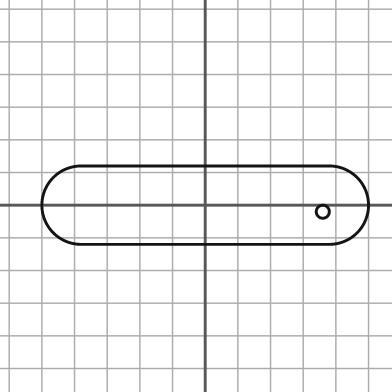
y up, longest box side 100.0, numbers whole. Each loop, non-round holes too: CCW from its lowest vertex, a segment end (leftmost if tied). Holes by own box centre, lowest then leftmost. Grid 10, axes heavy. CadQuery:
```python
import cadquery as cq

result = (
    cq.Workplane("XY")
    .moveTo(-38.0, -12.0)
    .lineTo(38.0, -12.0)
    .threePointArc((50.0, 0.0), (38.0, 12.0))
    .lineTo(-38.0, 12.0)
    .threePointArc((-50.0, 0.0), (-38.0, -12.0))
    .close()
    .moveTo(36.0, -2.0)
    .circle(2.0)
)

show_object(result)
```